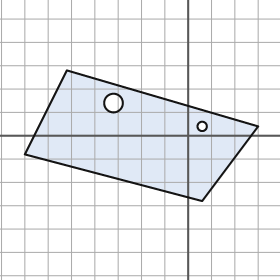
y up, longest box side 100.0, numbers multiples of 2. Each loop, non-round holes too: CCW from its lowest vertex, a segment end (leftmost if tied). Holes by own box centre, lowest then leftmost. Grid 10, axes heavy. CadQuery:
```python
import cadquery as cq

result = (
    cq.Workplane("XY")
    .moveTo(6.0, -28.0)
    .lineTo(30.0, 4.0)
    .lineTo(-52.0, 28.0)
    .lineTo(-70.0, -8.0)
    .close()
    .moveTo(6.0, 4.0)
    .circle(2.0)
    .moveTo(-32.0, 14.0)
    .circle(4.0)
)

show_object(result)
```